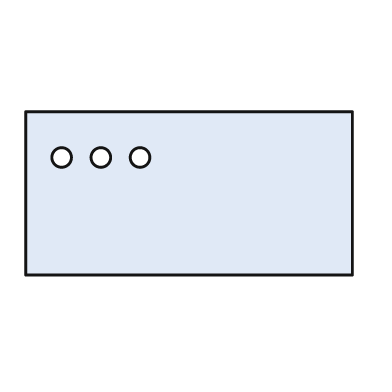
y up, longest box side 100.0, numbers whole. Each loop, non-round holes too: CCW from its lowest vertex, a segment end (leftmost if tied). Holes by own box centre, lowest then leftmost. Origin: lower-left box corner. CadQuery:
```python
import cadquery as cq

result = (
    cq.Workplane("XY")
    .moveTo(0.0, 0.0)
    .lineTo(100.0, 0.0)
    .lineTo(100.0, 50.0)
    .lineTo(0.0, 50.0)
    .close()
    .moveTo(11.0, 36.0)
    .circle(3.0)
    .moveTo(23.0, 36.0)
    .circle(3.0)
    .moveTo(35.0, 36.0)
    .circle(3.0)
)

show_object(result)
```